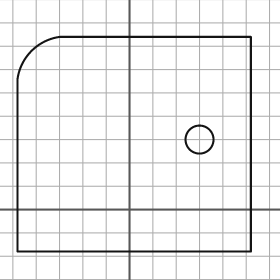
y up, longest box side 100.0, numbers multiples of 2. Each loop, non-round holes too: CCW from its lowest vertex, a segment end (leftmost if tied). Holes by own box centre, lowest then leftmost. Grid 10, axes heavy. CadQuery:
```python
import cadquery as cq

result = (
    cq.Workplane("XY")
    .moveTo(-48.0, -18.0)
    .lineTo(52.0, -18.0)
    .lineTo(52.0, 74.0)
    .lineTo(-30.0, 74.0)
    .threePointArc((-42.0, 68.0), (-48.0, 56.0))
    .close()
    .moveTo(30.0, 30.0)
    .circle(6.0)
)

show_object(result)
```